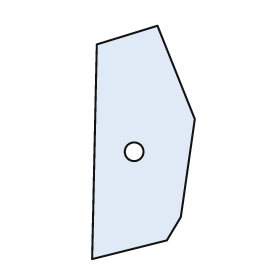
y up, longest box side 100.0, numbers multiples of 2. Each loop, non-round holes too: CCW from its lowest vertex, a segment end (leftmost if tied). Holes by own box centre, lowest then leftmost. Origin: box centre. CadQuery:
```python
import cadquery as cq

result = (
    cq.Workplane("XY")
    .moveTo(-22.0, -50.0)
    .lineTo(10.0, -42.0)
    .lineTo(16.0, -32.0)
    .lineTo(22.0, 10.0)
    .lineTo(6.0, 50.0)
    .lineTo(-20.0, 42.0)
    .close()
    .moveTo(-4.0, -4.0)
    .circle(4.0)
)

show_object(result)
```